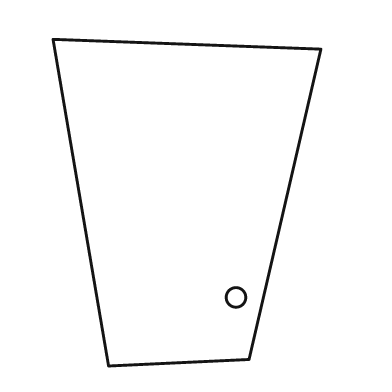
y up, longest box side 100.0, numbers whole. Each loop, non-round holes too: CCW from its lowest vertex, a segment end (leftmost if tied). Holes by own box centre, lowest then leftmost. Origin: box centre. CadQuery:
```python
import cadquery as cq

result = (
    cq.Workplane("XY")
    .moveTo(-24.0, -50.0)
    .lineTo(19.0, -48.0)
    .lineTo(41.0, 47.0)
    .lineTo(-41.0, 50.0)
    .close()
    .moveTo(15.0, -29.0)
    .circle(3.0)
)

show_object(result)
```